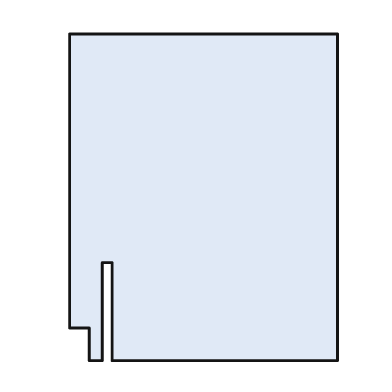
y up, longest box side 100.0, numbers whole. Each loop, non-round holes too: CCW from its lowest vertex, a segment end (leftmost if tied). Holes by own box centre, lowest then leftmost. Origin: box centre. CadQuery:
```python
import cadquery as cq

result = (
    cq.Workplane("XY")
    .moveTo(-35.0, -50.0)
    .lineTo(-31.0, -50.0)
    .lineTo(-31.0, -20.0)
    .lineTo(-28.0, -20.0)
    .lineTo(-28.0, -50.0)
    .lineTo(41.0, -50.0)
    .lineTo(41.0, 50.0)
    .lineTo(-41.0, 50.0)
    .lineTo(-41.0, -40.0)
    .lineTo(-35.0, -40.0)
    .close()
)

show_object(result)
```